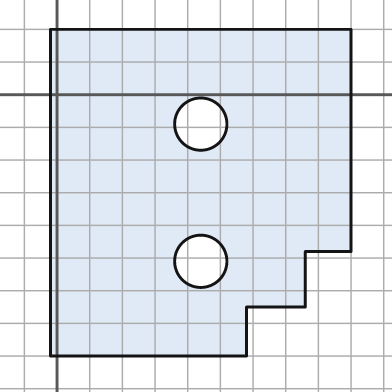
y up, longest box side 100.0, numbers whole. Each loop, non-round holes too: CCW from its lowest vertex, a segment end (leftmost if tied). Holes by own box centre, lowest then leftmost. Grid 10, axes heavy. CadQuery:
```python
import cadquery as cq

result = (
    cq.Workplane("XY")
    .moveTo(-2.0, -80.0)
    .lineTo(58.0, -80.0)
    .lineTo(58.0, -65.0)
    .lineTo(76.0, -65.0)
    .lineTo(76.0, -48.0)
    .lineTo(90.0, -48.0)
    .lineTo(90.0, 20.0)
    .lineTo(-2.0, 20.0)
    .close()
    .moveTo(44.0, -51.0)
    .circle(8.0)
    .moveTo(44.0, -9.0)
    .circle(8.0)
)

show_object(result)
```